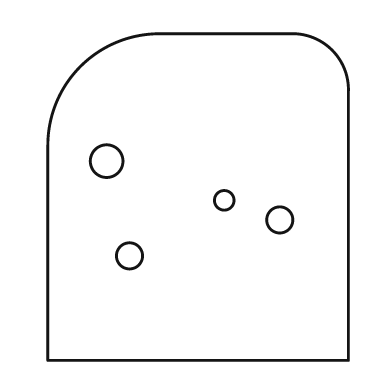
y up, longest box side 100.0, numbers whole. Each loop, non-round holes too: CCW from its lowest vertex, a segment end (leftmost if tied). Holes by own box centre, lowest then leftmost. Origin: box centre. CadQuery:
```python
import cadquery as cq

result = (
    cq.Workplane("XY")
    .moveTo(-46.0, -50.0)
    .lineTo(46.0, -50.0)
    .lineTo(46.0, 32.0)
    .threePointArc((41.0, 45.0), (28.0, 50.0))
    .lineTo(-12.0, 50.0)
    .threePointArc((-36.0, 40.0), (-46.0, 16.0))
    .close()
    .moveTo(-21.0, -18.0)
    .circle(4.0)
    .moveTo(25.0, -7.0)
    .circle(4.0)
    .moveTo(8.0, -1.0)
    .circle(3.0)
    .moveTo(-28.0, 11.0)
    .circle(5.0)
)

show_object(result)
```